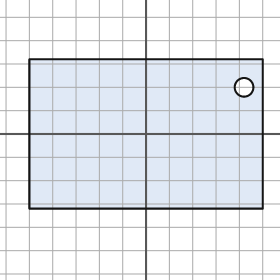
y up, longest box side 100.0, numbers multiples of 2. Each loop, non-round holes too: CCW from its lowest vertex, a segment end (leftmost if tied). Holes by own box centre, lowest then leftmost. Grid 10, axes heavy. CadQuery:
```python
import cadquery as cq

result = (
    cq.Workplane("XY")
    .moveTo(-50.0, -32.0)
    .lineTo(50.0, -32.0)
    .lineTo(50.0, 32.0)
    .lineTo(-50.0, 32.0)
    .close()
    .moveTo(42.0, 20.0)
    .circle(4.0)
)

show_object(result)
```